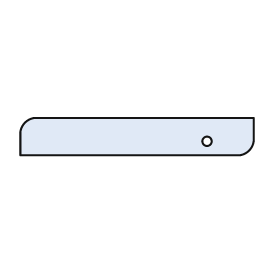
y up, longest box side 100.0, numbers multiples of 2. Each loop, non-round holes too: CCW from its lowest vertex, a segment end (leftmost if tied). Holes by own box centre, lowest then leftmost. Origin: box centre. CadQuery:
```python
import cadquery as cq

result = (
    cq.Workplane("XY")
    .moveTo(-50.0, -8.0)
    .lineTo(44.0, -8.0)
    .threePointArc((48.0, -6.0), (50.0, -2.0))
    .lineTo(50.0, 8.0)
    .lineTo(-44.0, 8.0)
    .threePointArc((-48.0, 6.0), (-50.0, 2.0))
    .close()
    .moveTo(30.0, -2.0)
    .circle(2.0)
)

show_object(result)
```